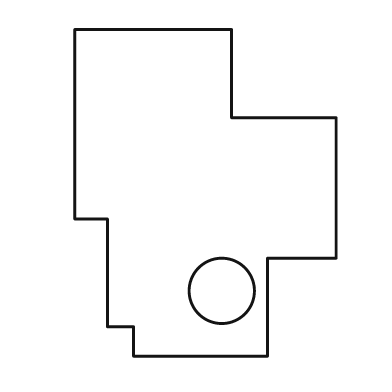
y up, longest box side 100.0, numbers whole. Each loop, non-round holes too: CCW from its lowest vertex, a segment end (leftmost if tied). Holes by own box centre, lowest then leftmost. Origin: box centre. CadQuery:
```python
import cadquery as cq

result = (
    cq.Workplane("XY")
    .moveTo(-22.0, -50.0)
    .lineTo(19.0, -50.0)
    .lineTo(19.0, -20.0)
    .lineTo(40.0, -20.0)
    .lineTo(40.0, 23.0)
    .lineTo(8.0, 23.0)
    .lineTo(8.0, 50.0)
    .lineTo(-40.0, 50.0)
    .lineTo(-40.0, -8.0)
    .lineTo(-30.0, -8.0)
    .lineTo(-30.0, -41.0)
    .lineTo(-22.0, -41.0)
    .close()
    .moveTo(5.0, -30.0)
    .circle(10.0)
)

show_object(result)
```